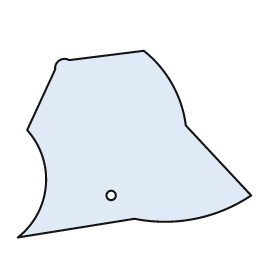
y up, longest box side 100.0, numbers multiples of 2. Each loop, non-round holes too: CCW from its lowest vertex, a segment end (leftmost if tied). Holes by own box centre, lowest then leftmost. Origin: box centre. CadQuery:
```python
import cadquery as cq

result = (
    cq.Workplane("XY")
    .moveTo(-50.0, -40.0)
    .lineTo(0.0, -32.0)
    .threePointArc((26.0, -32.0), (50.0, -22.0))
    .lineTo(22.0, 8.0)
    .threePointArc((16.0, 26.0), (4.0, 40.0))
    .lineTo(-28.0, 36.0)
    .threePointArc((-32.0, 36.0), (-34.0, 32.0))
    .lineTo(-46.0, 6.0)
    .threePointArc((-38.0, -18.0), (-50.0, -40.0))
    .close()
    .moveTo(-10.0, -22.0)
    .circle(2.0)
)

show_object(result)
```